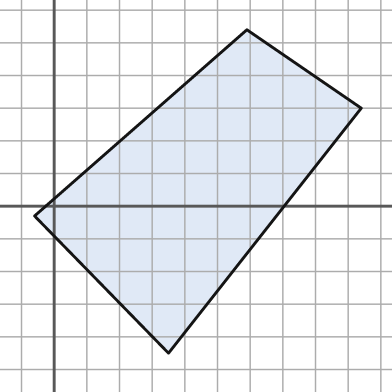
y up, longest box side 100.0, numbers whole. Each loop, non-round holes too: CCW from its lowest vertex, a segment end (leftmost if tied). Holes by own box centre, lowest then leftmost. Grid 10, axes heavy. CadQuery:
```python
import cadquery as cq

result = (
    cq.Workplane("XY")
    .moveTo(35.0, -45.0)
    .lineTo(94.0, 30.0)
    .lineTo(59.0, 54.0)
    .lineTo(-6.0, -3.0)
    .close()
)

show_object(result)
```